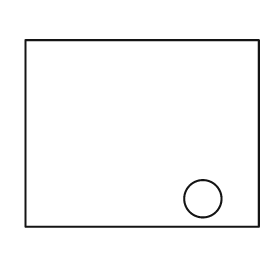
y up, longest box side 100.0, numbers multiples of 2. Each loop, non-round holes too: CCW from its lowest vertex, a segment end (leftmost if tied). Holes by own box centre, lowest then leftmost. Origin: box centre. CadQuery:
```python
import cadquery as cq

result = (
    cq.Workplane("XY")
    .moveTo(-50.0, -40.0)
    .lineTo(50.0, -40.0)
    .lineTo(50.0, 40.0)
    .lineTo(-50.0, 40.0)
    .close()
    .moveTo(26.0, -28.0)
    .circle(8.0)
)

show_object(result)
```